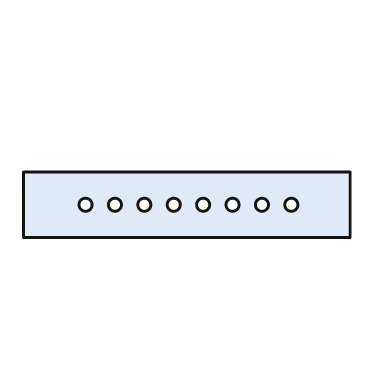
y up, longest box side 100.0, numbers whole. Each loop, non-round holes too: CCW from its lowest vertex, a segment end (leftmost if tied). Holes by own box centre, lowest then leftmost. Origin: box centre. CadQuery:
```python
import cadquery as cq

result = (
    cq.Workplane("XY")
    .moveTo(-50.0, -10.0)
    .lineTo(50.0, -10.0)
    .lineTo(50.0, 10.0)
    .lineTo(-50.0, 10.0)
    .close()
    .moveTo(-31.0, 0.0)
    .circle(2.0)
    .moveTo(-22.0, 0.0)
    .circle(2.0)
    .moveTo(-13.0, 0.0)
    .circle(2.0)
    .moveTo(-4.0, 0.0)
    .circle(2.0)
    .moveTo(5.0, 0.0)
    .circle(2.0)
    .moveTo(14.0, 0.0)
    .circle(2.0)
    .moveTo(23.0, 0.0)
    .circle(2.0)
    .moveTo(32.0, 0.0)
    .circle(2.0)
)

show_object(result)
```